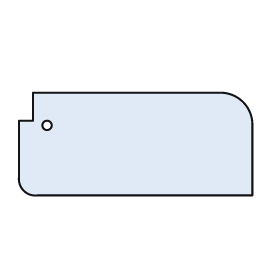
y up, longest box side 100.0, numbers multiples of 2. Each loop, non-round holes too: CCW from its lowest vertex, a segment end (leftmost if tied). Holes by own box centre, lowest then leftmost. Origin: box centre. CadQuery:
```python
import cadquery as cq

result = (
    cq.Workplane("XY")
    .moveTo(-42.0, -22.0)
    .lineTo(50.0, -22.0)
    .lineTo(50.0, 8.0)
    .threePointArc((46.0, 18.0), (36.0, 22.0))
    .lineTo(-44.0, 22.0)
    .lineTo(-44.0, 10.0)
    .lineTo(-50.0, 10.0)
    .lineTo(-50.0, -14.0)
    .threePointArc((-48.0, -20.0), (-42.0, -22.0))
    .close()
    .moveTo(-38.0, 8.0)
    .circle(2.0)
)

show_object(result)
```